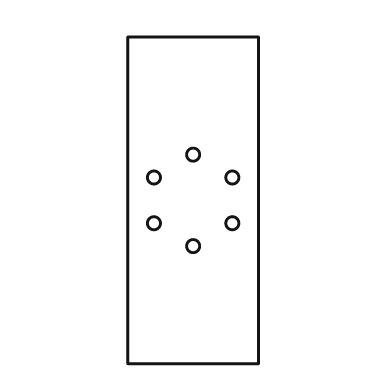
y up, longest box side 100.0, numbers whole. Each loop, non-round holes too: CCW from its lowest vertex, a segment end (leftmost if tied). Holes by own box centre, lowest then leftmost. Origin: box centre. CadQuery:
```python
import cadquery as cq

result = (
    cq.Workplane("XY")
    .moveTo(-20.0, -50.0)
    .lineTo(20.0, -50.0)
    .lineTo(20.0, 50.0)
    .lineTo(-20.0, 50.0)
    .close()
    .moveTo(0.0, -14.0)
    .circle(2.0)
    .moveTo(-12.0, -7.0)
    .circle(2.0)
    .moveTo(12.0, -7.0)
    .circle(2.0)
    .moveTo(-12.0, 7.0)
    .circle(2.0)
    .moveTo(12.0, 7.0)
    .circle(2.0)
    .moveTo(0.0, 14.0)
    .circle(2.0)
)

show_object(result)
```